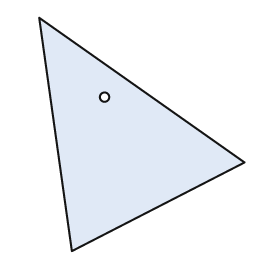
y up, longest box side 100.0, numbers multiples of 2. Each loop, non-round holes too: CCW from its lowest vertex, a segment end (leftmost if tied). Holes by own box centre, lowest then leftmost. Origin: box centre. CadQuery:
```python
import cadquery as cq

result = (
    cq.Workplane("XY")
    .moveTo(-30.0, -50.0)
    .lineTo(44.0, -12.0)
    .lineTo(-44.0, 50.0)
    .close()
    .moveTo(-16.0, 16.0)
    .circle(2.0)
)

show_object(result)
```